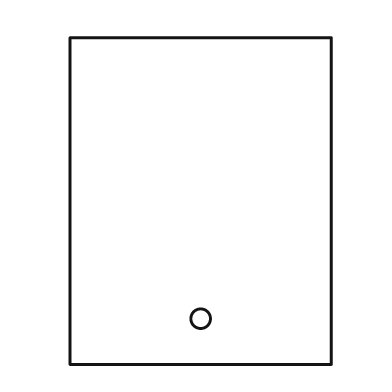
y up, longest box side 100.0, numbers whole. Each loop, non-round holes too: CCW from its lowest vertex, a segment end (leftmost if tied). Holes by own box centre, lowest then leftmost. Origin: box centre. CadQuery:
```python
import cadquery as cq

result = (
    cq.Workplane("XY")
    .moveTo(-40.0, -50.0)
    .lineTo(40.0, -50.0)
    .lineTo(40.0, 50.0)
    .lineTo(-40.0, 50.0)
    .close()
    .moveTo(0.0, -36.0)
    .circle(3.0)
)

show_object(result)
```